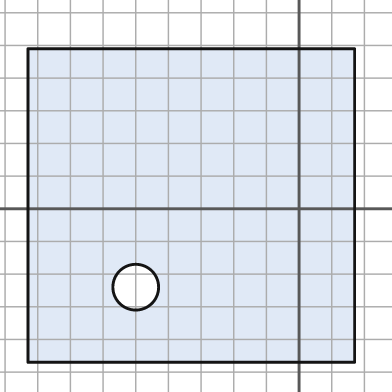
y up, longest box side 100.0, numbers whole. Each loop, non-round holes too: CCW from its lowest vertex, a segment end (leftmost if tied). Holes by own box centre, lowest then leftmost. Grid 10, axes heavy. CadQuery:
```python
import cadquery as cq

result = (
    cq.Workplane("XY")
    .moveTo(-83.0, -47.0)
    .lineTo(17.0, -47.0)
    .lineTo(17.0, 49.0)
    .lineTo(-83.0, 49.0)
    .close()
    .moveTo(-50.0, -24.0)
    .circle(7.0)
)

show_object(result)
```